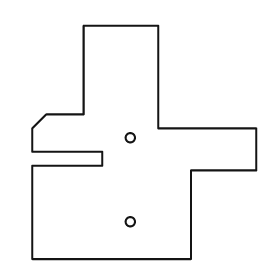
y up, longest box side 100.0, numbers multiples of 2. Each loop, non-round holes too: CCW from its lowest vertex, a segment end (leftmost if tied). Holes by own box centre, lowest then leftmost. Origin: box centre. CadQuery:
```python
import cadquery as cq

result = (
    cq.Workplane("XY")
    .moveTo(-48.0, -50.0)
    .lineTo(20.0, -50.0)
    .lineTo(20.0, -12.0)
    .lineTo(48.0, -12.0)
    .lineTo(48.0, 6.0)
    .lineTo(6.0, 6.0)
    .lineTo(6.0, 50.0)
    .lineTo(-26.0, 50.0)
    .lineTo(-26.0, 12.0)
    .lineTo(-42.0, 12.0)
    .lineTo(-48.0, 6.0)
    .lineTo(-48.0, -4.0)
    .lineTo(-18.0, -4.0)
    .lineTo(-18.0, -10.0)
    .lineTo(-48.0, -10.0)
    .close()
    .moveTo(-6.0, -34.0)
    .circle(2.0)
    .moveTo(-6.0, 2.0)
    .circle(2.0)
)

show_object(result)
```